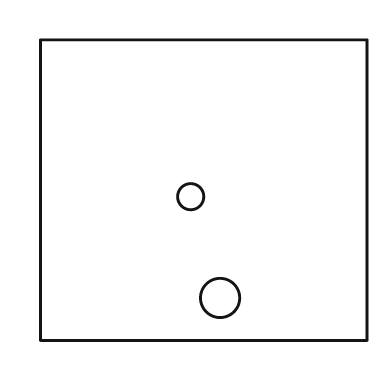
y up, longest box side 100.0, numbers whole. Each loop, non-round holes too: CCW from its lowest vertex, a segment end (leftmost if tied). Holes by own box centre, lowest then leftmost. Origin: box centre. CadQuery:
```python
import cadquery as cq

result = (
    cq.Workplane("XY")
    .moveTo(-50.0, -46.0)
    .lineTo(50.0, -46.0)
    .lineTo(50.0, 46.0)
    .lineTo(-50.0, 46.0)
    .close()
    .moveTo(5.0, -33.0)
    .circle(6.0)
    .moveTo(-4.0, -2.0)
    .circle(4.0)
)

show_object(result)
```